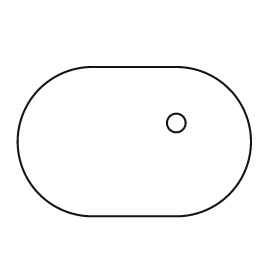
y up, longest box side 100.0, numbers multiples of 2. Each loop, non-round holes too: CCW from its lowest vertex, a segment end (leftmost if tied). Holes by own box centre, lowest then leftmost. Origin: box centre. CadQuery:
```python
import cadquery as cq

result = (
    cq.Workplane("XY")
    .moveTo(-18.0, -32.0)
    .lineTo(18.0, -32.0)
    .threePointArc((50.0, 0.0), (18.0, 32.0))
    .lineTo(-18.0, 32.0)
    .threePointArc((-50.0, 0.0), (-18.0, -32.0))
    .close()
    .moveTo(18.0, 8.0)
    .circle(4.0)
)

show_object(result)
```